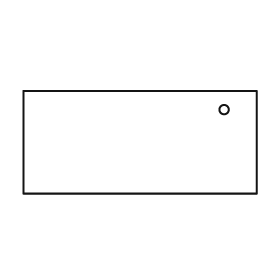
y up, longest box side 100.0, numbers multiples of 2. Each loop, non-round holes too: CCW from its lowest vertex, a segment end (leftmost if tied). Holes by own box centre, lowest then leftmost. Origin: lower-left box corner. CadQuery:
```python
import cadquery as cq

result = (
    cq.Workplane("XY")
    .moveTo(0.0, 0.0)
    .lineTo(100.0, 0.0)
    .lineTo(100.0, 44.0)
    .lineTo(0.0, 44.0)
    .close()
    .moveTo(86.0, 36.0)
    .circle(2.0)
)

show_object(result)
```